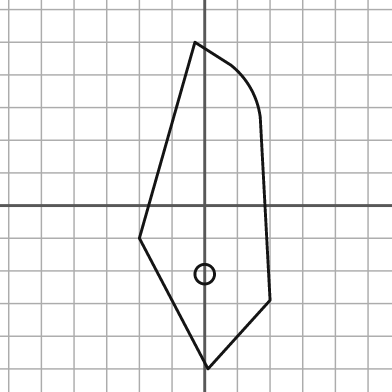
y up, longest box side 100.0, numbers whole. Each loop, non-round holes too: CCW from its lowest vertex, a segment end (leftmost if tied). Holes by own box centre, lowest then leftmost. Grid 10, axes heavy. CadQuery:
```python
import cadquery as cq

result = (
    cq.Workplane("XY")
    .moveTo(1.0, -50.0)
    .lineTo(20.0, -29.0)
    .lineTo(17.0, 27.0)
    .threePointArc((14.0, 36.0), (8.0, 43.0))
    .lineTo(-3.0, 50.0)
    .lineTo(-20.0, -10.0)
    .close()
    .moveTo(0.0, -21.0)
    .circle(3.0)
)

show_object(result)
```